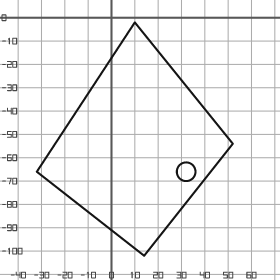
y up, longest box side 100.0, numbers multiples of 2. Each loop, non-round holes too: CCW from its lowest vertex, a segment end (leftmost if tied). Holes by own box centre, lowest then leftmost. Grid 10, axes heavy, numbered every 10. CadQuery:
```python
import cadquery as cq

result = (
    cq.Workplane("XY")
    .moveTo(14.0, -102.0)
    .lineTo(52.0, -54.0)
    .lineTo(10.0, -2.0)
    .lineTo(-32.0, -66.0)
    .close()
    .moveTo(32.0, -66.0)
    .circle(4.0)
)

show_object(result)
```